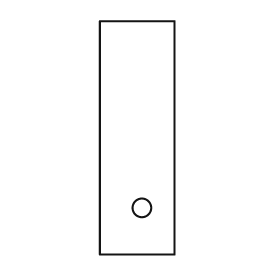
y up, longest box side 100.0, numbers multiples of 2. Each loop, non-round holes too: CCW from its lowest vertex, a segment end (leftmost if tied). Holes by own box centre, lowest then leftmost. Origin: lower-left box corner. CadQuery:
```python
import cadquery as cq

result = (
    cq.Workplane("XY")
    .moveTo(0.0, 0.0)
    .lineTo(32.0, 0.0)
    .lineTo(32.0, 100.0)
    .lineTo(0.0, 100.0)
    .close()
    .moveTo(18.0, 20.0)
    .circle(4.0)
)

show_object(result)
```